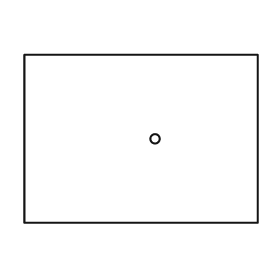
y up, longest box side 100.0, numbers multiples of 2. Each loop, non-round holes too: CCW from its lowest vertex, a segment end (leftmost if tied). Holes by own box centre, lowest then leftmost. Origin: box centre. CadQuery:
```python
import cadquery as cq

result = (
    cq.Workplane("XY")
    .moveTo(-50.0, -36.0)
    .lineTo(50.0, -36.0)
    .lineTo(50.0, 36.0)
    .lineTo(-50.0, 36.0)
    .close()
    .moveTo(6.0, 0.0)
    .circle(2.0)
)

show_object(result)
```